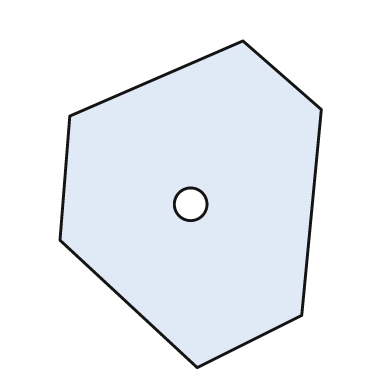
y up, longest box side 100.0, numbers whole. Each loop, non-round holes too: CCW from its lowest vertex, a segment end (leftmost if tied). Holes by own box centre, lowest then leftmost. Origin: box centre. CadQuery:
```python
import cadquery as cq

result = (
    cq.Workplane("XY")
    .moveTo(2.0, -50.0)
    .lineTo(34.0, -34.0)
    .lineTo(40.0, 29.0)
    .lineTo(16.0, 50.0)
    .lineTo(-37.0, 27.0)
    .lineTo(-40.0, -11.0)
    .close()
    .moveTo(0.0, 0.0)
    .circle(5.0)
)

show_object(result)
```